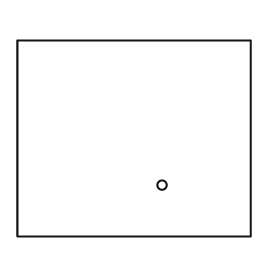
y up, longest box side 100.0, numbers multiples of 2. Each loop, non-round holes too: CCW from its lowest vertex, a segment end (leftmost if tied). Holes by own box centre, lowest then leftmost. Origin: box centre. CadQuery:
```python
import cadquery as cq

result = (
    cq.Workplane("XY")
    .moveTo(-50.0, -42.0)
    .lineTo(50.0, -42.0)
    .lineTo(50.0, 42.0)
    .lineTo(-50.0, 42.0)
    .close()
    .moveTo(12.0, -20.0)
    .circle(2.0)
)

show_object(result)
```